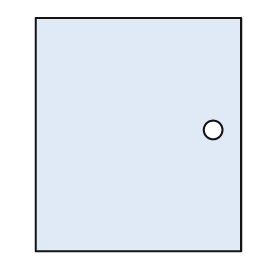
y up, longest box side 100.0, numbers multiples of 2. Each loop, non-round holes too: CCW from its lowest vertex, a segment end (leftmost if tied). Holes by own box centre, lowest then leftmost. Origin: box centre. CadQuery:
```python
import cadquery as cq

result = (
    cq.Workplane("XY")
    .moveTo(-44.0, -50.0)
    .lineTo(44.0, -50.0)
    .lineTo(44.0, 50.0)
    .lineTo(-44.0, 50.0)
    .close()
    .moveTo(32.0, 2.0)
    .circle(4.0)
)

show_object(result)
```